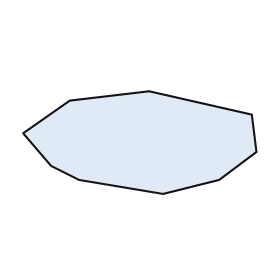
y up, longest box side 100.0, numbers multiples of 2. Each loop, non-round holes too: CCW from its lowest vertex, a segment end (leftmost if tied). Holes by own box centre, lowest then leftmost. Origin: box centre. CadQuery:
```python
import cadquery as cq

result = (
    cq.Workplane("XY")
    .moveTo(10.0, -22.0)
    .lineTo(34.0, -16.0)
    .lineTo(50.0, -4.0)
    .lineTo(48.0, 12.0)
    .lineTo(4.0, 22.0)
    .lineTo(-30.0, 18.0)
    .lineTo(-50.0, 4.0)
    .lineTo(-38.0, -10.0)
    .lineTo(-26.0, -16.0)
    .close()
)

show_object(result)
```